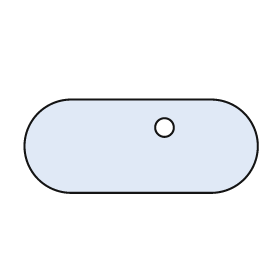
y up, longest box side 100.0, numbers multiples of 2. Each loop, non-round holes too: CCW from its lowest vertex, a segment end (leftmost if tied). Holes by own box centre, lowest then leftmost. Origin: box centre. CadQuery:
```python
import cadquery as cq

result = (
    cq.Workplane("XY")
    .moveTo(-30.0, -20.0)
    .lineTo(30.0, -20.0)
    .threePointArc((50.0, 0.0), (30.0, 20.0))
    .lineTo(-30.0, 20.0)
    .threePointArc((-50.0, 0.0), (-30.0, -20.0))
    .close()
    .moveTo(10.0, 8.0)
    .circle(4.0)
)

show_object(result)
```